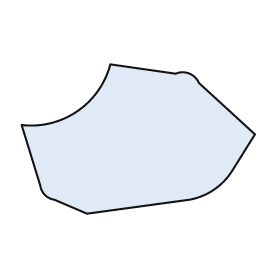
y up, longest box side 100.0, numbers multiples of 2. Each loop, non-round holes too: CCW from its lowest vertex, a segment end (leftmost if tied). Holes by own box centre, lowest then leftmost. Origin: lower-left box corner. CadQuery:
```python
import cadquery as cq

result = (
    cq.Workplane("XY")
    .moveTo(28.0, 0.0)
    .lineTo(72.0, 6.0)
    .threePointArc((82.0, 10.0), (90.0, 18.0))
    .lineTo(100.0, 34.0)
    .lineTo(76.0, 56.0)
    .threePointArc((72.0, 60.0), (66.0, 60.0))
    .lineTo(38.0, 64.0)
    .threePointArc((24.0, 44.0), (0.0, 38.0))
    .lineTo(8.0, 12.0)
    .threePointArc((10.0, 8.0), (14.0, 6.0))
    .close()
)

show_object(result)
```